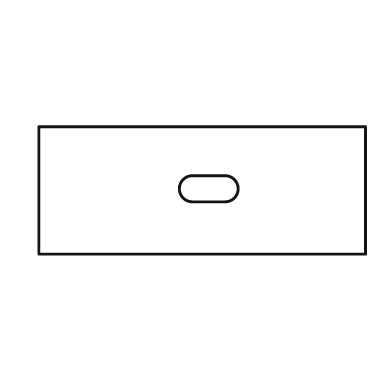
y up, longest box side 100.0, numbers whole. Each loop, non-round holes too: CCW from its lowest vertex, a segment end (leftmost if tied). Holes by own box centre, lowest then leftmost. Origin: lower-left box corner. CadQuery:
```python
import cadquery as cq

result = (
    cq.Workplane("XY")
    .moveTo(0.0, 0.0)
    .lineTo(100.0, 0.0)
    .lineTo(100.0, 39.0)
    .lineTo(0.0, 39.0)
    .close()
    .moveTo(47.0, 16.0)
    .lineTo(57.0, 16.0)
    .threePointArc((61.0, 20.0), (57.0, 24.0))
    .lineTo(47.0, 24.0)
    .threePointArc((43.0, 20.0), (47.0, 16.0))
    .close()
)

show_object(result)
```